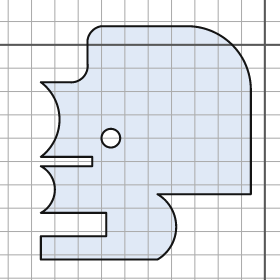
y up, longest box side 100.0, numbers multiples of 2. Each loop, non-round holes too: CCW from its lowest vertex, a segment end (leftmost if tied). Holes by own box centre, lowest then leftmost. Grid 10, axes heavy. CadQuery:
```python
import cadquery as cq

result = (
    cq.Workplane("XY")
    .moveTo(-96.0, -92.0)
    .lineTo(-46.0, -92.0)
    .threePointArc((-38.0, -78.0), (-46.0, -64.0))
    .lineTo(-6.0, -64.0)
    .lineTo(-6.0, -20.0)
    .threePointArc((-14.0, 0.0), (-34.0, 8.0))
    .lineTo(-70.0, 8.0)
    .threePointArc((-74.0, 6.0), (-76.0, 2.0))
    .lineTo(-76.0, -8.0)
    .threePointArc((-78.0, -14.0), (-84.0, -16.0))
    .lineTo(-96.0, -16.0)
    .threePointArc((-88.0, -32.0), (-96.0, -48.0))
    .lineTo(-74.0, -48.0)
    .lineTo(-74.0, -52.0)
    .lineTo(-96.0, -52.0)
    .threePointArc((-90.0, -62.0), (-96.0, -72.0))
    .lineTo(-68.0, -72.0)
    .lineTo(-68.0, -82.0)
    .lineTo(-96.0, -82.0)
    .close()
    .moveTo(-66.0, -40.0)
    .circle(4.0)
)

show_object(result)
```